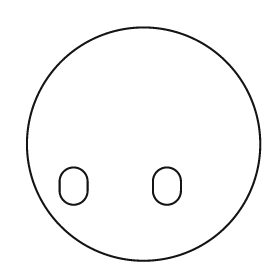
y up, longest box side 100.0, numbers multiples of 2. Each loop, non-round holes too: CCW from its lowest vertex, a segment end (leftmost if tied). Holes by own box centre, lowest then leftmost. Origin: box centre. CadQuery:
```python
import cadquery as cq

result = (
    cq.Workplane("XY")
    .moveTo(0.0, 0.0)
    .circle(50.0)
    .moveTo(-36.0, -20.0)
    .threePointArc((-30.0, -26.0), (-24.0, -20.0))
    .lineTo(-24.0, -16.0)
    .threePointArc((-30.0, -10.0), (-36.0, -16.0))
    .close()
    .moveTo(4.0, -20.0)
    .threePointArc((10.0, -26.0), (16.0, -20.0))
    .lineTo(16.0, -16.0)
    .threePointArc((10.0, -10.0), (4.0, -16.0))
    .close()
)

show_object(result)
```